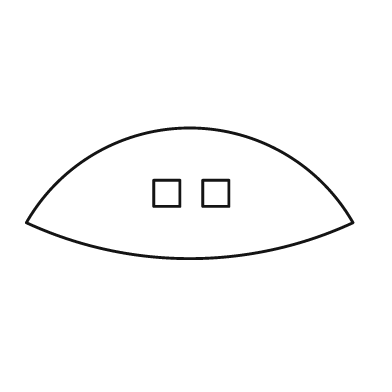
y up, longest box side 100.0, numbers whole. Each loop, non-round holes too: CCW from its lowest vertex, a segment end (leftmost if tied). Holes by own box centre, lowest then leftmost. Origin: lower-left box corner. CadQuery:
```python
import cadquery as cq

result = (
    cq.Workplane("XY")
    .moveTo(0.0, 11.0)
    .threePointArc((50.0, 0.0), (100.0, 11.0))
    .threePointArc((50.0, 40.0), (0.0, 11.0))
    .close()
    .moveTo(39.0, 16.0)
    .lineTo(47.0, 16.0)
    .lineTo(47.0, 24.0)
    .lineTo(39.0, 24.0)
    .close()
    .moveTo(54.0, 16.0)
    .lineTo(62.0, 16.0)
    .lineTo(62.0, 24.0)
    .lineTo(54.0, 24.0)
    .close()
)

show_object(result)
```